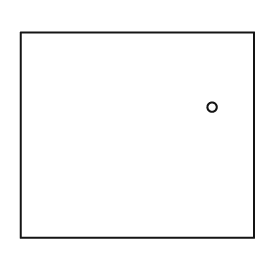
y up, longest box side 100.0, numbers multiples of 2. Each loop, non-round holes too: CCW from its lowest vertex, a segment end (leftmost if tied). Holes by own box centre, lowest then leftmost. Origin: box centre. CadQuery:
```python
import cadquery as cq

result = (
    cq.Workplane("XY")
    .moveTo(-50.0, -44.0)
    .lineTo(50.0, -44.0)
    .lineTo(50.0, 44.0)
    .lineTo(-50.0, 44.0)
    .close()
    .moveTo(32.0, 12.0)
    .circle(2.0)
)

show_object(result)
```